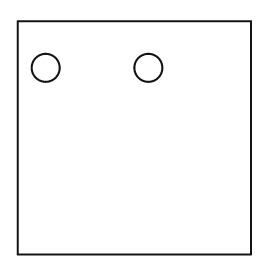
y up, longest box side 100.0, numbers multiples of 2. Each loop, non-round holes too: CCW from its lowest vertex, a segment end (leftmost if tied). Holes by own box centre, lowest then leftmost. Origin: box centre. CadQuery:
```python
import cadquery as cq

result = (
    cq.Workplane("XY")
    .moveTo(-50.0, -50.0)
    .lineTo(50.0, -50.0)
    .lineTo(50.0, 50.0)
    .lineTo(-50.0, 50.0)
    .close()
    .moveTo(-38.0, 30.0)
    .circle(6.0)
    .moveTo(6.0, 30.0)
    .circle(6.0)
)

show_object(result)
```